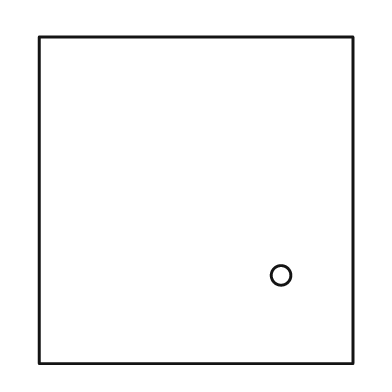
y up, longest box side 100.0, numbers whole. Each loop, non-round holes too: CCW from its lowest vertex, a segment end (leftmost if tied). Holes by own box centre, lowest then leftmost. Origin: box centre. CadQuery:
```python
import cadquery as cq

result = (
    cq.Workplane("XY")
    .moveTo(-48.0, -50.0)
    .lineTo(48.0, -50.0)
    .lineTo(48.0, 50.0)
    .lineTo(-48.0, 50.0)
    .close()
    .moveTo(26.0, -23.0)
    .circle(3.0)
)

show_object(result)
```